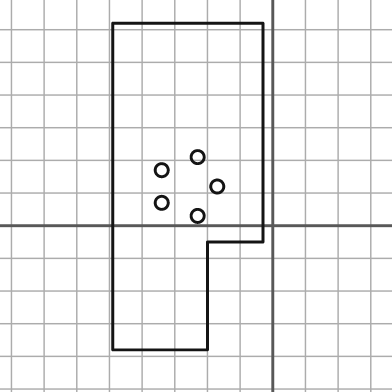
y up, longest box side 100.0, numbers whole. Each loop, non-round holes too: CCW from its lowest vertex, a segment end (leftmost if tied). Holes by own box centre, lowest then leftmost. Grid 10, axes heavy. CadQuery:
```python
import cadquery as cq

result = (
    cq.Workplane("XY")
    .moveTo(-49.0, -38.0)
    .lineTo(-20.0, -38.0)
    .lineTo(-20.0, -5.0)
    .lineTo(-3.0, -5.0)
    .lineTo(-3.0, 62.0)
    .lineTo(-49.0, 62.0)
    .close()
    .moveTo(-23.0, 3.0)
    .circle(2.0)
    .moveTo(-34.0, 7.0)
    .circle(2.0)
    .moveTo(-17.0, 12.0)
    .circle(2.0)
    .moveTo(-34.0, 17.0)
    .circle(2.0)
    .moveTo(-23.0, 21.0)
    .circle(2.0)
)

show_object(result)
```